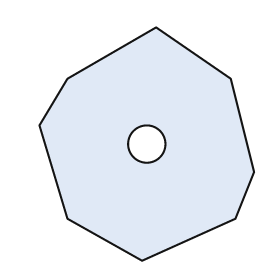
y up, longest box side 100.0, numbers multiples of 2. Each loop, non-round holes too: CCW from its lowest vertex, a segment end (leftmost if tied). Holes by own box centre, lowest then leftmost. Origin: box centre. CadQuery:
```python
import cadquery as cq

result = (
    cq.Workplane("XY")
    .moveTo(-2.0, -50.0)
    .lineTo(38.0, -32.0)
    .lineTo(46.0, -12.0)
    .lineTo(36.0, 28.0)
    .lineTo(4.0, 50.0)
    .lineTo(-34.0, 28.0)
    .lineTo(-46.0, 8.0)
    .lineTo(-34.0, -32.0)
    .close()
    .moveTo(0.0, 0.0)
    .circle(8.0)
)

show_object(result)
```